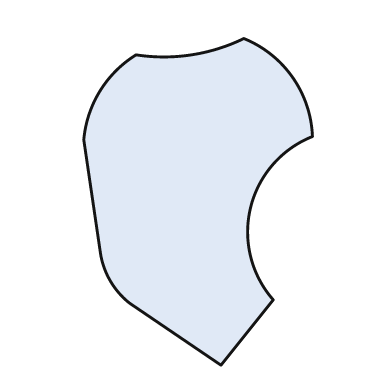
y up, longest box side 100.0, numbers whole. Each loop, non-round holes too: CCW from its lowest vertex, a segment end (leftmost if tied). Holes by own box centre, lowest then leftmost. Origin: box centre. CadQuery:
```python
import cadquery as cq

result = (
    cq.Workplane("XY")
    .moveTo(7.0, -50.0)
    .lineTo(23.0, -30.0)
    .threePointArc((16.0, -2.0), (35.0, 20.0))
    .threePointArc((29.0, 38.0), (14.0, 50.0))
    .threePointArc((-2.0, 45.0), (-19.0, 45.0))
    .threePointArc((-30.0, 34.0), (-35.0, 19.0))
    .lineTo(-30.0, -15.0)
    .threePointArc((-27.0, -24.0), (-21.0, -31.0))
    .close()
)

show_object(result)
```